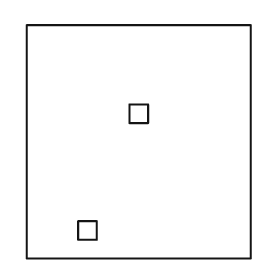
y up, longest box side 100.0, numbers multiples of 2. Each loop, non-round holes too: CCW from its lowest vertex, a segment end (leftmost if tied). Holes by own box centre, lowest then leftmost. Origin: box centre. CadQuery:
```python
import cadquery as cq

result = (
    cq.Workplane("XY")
    .moveTo(-48.0, -50.0)
    .lineTo(48.0, -50.0)
    .lineTo(48.0, 50.0)
    .lineTo(-48.0, 50.0)
    .close()
    .moveTo(-26.0, -42.0)
    .lineTo(-18.0, -42.0)
    .lineTo(-18.0, -34.0)
    .lineTo(-26.0, -34.0)
    .close()
    .moveTo(-4.0, 8.0)
    .lineTo(4.0, 8.0)
    .lineTo(4.0, 16.0)
    .lineTo(-4.0, 16.0)
    .close()
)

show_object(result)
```